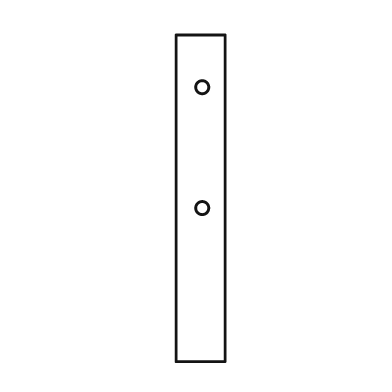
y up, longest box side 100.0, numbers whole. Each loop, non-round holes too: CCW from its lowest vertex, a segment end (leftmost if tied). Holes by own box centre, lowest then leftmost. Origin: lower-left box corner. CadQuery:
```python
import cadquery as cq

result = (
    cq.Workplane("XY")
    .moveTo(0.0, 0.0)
    .lineTo(15.0, 0.0)
    .lineTo(15.0, 100.0)
    .lineTo(0.0, 100.0)
    .close()
    .moveTo(8.0, 47.0)
    .circle(2.0)
    .moveTo(8.0, 84.0)
    .circle(2.0)
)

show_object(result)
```